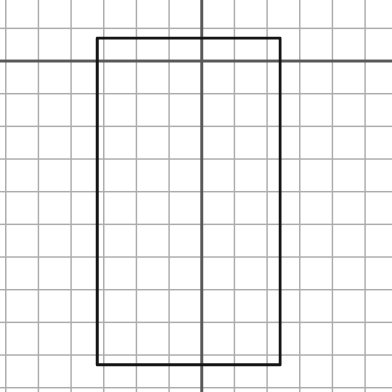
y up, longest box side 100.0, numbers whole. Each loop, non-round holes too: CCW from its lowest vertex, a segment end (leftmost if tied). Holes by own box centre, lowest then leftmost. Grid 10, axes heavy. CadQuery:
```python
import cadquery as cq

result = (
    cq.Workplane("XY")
    .moveTo(-32.0, -93.0)
    .lineTo(24.0, -93.0)
    .lineTo(24.0, 7.0)
    .lineTo(-32.0, 7.0)
    .close()
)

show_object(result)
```